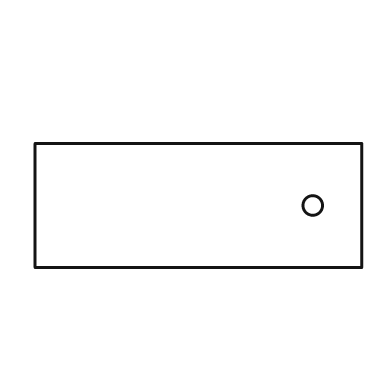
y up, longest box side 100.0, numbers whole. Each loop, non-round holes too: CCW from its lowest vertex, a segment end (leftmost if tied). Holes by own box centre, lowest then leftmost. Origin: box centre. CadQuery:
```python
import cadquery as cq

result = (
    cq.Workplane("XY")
    .moveTo(-50.0, -19.0)
    .lineTo(50.0, -19.0)
    .lineTo(50.0, 19.0)
    .lineTo(-50.0, 19.0)
    .close()
    .moveTo(35.0, 0.0)
    .circle(3.0)
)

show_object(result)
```